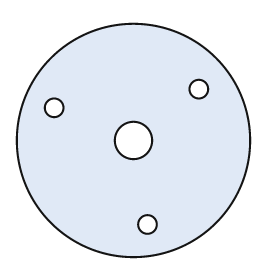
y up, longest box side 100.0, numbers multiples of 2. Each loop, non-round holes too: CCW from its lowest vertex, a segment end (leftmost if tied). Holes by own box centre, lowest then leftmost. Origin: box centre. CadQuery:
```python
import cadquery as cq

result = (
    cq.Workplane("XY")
    .moveTo(0.0, 0.0)
    .circle(50.0)
    .moveTo(6.0, -36.0)
    .circle(4.0)
    .moveTo(0.0, 0.0)
    .circle(8.0)
    .moveTo(-34.0, 14.0)
    .circle(4.0)
    .moveTo(28.0, 22.0)
    .circle(4.0)
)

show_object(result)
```